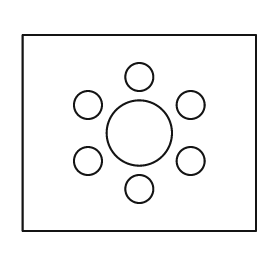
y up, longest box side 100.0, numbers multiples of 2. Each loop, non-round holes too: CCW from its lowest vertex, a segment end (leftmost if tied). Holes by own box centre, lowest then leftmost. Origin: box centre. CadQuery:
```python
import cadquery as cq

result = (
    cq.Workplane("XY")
    .moveTo(-50.0, -42.0)
    .lineTo(50.0, -42.0)
    .lineTo(50.0, 42.0)
    .lineTo(-50.0, 42.0)
    .close()
    .moveTo(0.0, -24.0)
    .circle(6.0)
    .moveTo(-22.0, -12.0)
    .circle(6.0)
    .moveTo(22.0, -12.0)
    .circle(6.0)
    .moveTo(0.0, 0.0)
    .circle(14.0)
    .moveTo(-22.0, 12.0)
    .circle(6.0)
    .moveTo(22.0, 12.0)
    .circle(6.0)
    .moveTo(0.0, 24.0)
    .circle(6.0)
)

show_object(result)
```